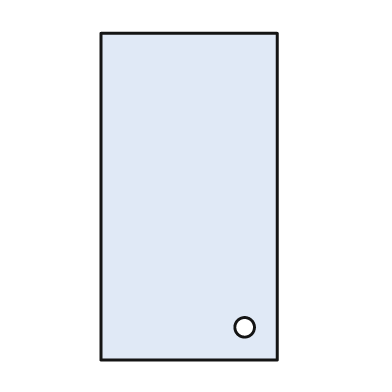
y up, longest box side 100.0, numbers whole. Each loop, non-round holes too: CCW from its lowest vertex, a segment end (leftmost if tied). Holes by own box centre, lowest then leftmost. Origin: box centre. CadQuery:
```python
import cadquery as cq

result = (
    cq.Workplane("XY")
    .moveTo(-27.0, -50.0)
    .lineTo(27.0, -50.0)
    .lineTo(27.0, 50.0)
    .lineTo(-27.0, 50.0)
    .close()
    .moveTo(17.0, -40.0)
    .circle(3.0)
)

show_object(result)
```